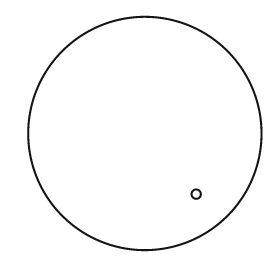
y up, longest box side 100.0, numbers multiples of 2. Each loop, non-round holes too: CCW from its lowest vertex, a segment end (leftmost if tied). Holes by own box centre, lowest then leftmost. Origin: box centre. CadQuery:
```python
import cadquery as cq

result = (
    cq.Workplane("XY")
    .moveTo(0.0, 0.0)
    .circle(50.0)
    .moveTo(22.0, -26.0)
    .circle(2.0)
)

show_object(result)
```